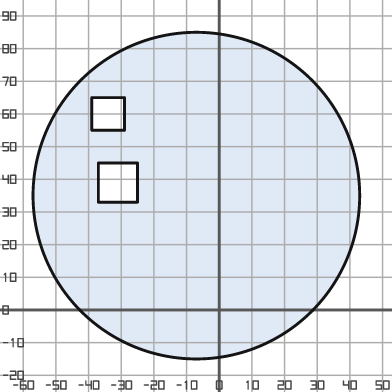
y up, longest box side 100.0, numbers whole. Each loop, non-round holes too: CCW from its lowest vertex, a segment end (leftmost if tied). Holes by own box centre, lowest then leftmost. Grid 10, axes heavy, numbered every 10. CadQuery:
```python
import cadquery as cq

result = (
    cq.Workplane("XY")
    .moveTo(-7.0, 35.0)
    .circle(50.0)
    .moveTo(-37.0, 33.0)
    .lineTo(-25.0, 33.0)
    .lineTo(-25.0, 45.0)
    .lineTo(-37.0, 45.0)
    .close()
    .moveTo(-39.0, 55.0)
    .lineTo(-29.0, 55.0)
    .lineTo(-29.0, 65.0)
    .lineTo(-39.0, 65.0)
    .close()
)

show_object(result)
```